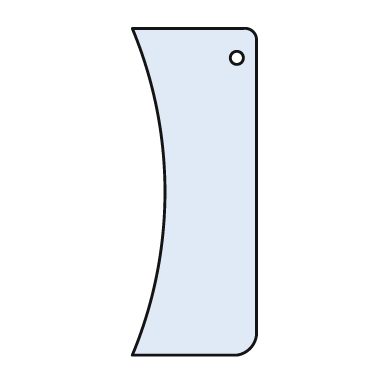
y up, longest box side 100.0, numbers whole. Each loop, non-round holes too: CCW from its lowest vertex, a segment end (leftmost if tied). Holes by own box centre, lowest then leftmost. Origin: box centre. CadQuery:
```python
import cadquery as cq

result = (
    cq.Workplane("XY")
    .moveTo(-19.0, -50.0)
    .lineTo(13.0, -50.0)
    .threePointArc((17.0, -48.0), (19.0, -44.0))
    .lineTo(19.0, 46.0)
    .threePointArc((18.0, 49.0), (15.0, 50.0))
    .lineTo(-19.0, 50.0)
    .threePointArc((-9.0, 0.0), (-19.0, -50.0))
    .close()
    .moveTo(13.0, 41.0)
    .circle(2.0)
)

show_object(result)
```